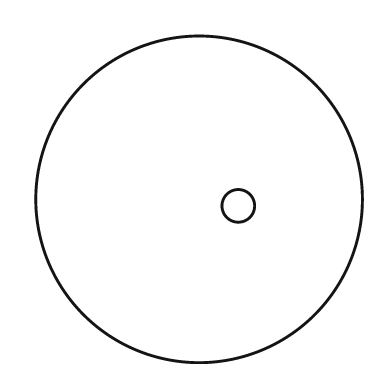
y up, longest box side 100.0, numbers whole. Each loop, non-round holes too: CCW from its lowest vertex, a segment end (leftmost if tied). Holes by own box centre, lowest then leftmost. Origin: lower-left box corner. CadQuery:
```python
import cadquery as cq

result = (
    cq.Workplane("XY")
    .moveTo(50.0, 50.0)
    .circle(50.0)
    .moveTo(62.0, 48.0)
    .circle(5.0)
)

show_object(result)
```